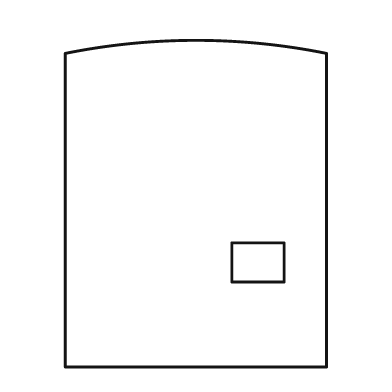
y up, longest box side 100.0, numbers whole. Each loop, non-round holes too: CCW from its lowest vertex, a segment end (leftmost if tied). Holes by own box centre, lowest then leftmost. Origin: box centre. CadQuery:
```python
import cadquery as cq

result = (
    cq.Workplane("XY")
    .moveTo(-40.0, -50.0)
    .lineTo(40.0, -50.0)
    .lineTo(40.0, 46.0)
    .threePointArc((0.0, 50.0), (-40.0, 46.0))
    .close()
    .moveTo(11.0, -24.0)
    .lineTo(27.0, -24.0)
    .lineTo(27.0, -12.0)
    .lineTo(11.0, -12.0)
    .close()
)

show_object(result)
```